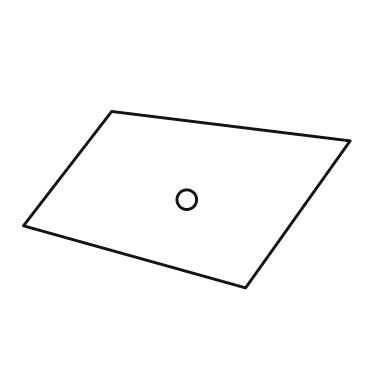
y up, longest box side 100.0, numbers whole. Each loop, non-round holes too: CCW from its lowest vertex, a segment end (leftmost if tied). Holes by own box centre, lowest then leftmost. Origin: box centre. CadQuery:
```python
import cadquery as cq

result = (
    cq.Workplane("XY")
    .moveTo(18.0, -27.0)
    .lineTo(50.0, 18.0)
    .lineTo(-23.0, 27.0)
    .lineTo(-50.0, -8.0)
    .close()
    .moveTo(0.0, 0.0)
    .circle(3.0)
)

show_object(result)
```